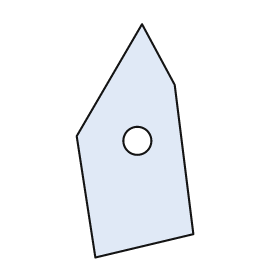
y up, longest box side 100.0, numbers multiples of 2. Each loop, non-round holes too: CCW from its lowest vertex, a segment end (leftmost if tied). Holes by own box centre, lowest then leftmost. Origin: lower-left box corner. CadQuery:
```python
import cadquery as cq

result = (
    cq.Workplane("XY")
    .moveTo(8.0, 0.0)
    .lineTo(50.0, 10.0)
    .lineTo(42.0, 74.0)
    .lineTo(28.0, 100.0)
    .lineTo(0.0, 52.0)
    .close()
    .moveTo(26.0, 50.0)
    .circle(6.0)
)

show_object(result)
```